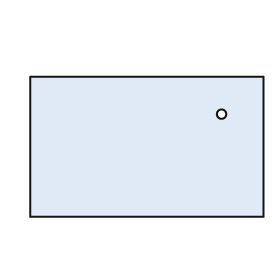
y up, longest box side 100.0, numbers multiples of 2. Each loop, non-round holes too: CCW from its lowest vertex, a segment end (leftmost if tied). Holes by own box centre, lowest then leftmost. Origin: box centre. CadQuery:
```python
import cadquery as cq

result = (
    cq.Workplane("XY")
    .moveTo(-50.0, -30.0)
    .lineTo(50.0, -30.0)
    .lineTo(50.0, 30.0)
    .lineTo(-50.0, 30.0)
    .close()
    .moveTo(32.0, 14.0)
    .circle(2.0)
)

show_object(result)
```